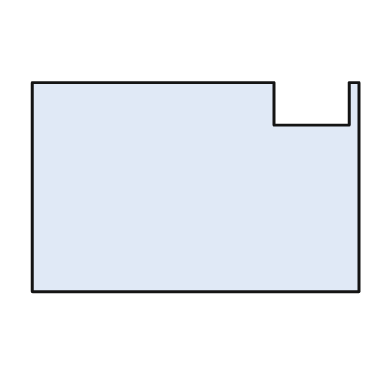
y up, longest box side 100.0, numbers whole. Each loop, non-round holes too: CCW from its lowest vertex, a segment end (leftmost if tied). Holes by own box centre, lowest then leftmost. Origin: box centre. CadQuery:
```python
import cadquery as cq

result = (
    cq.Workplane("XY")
    .moveTo(-50.0, -32.0)
    .lineTo(50.0, -32.0)
    .lineTo(50.0, 32.0)
    .lineTo(47.0, 32.0)
    .lineTo(47.0, 19.0)
    .lineTo(24.0, 19.0)
    .lineTo(24.0, 32.0)
    .lineTo(-50.0, 32.0)
    .close()
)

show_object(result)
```